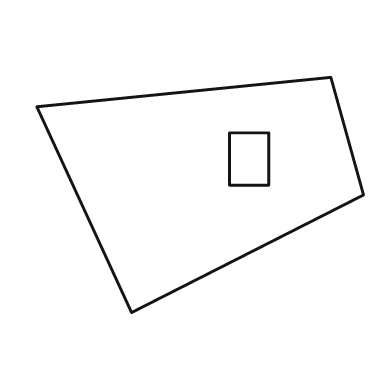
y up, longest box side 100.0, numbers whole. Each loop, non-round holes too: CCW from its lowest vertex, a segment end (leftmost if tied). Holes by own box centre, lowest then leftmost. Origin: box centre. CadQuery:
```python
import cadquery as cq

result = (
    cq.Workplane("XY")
    .moveTo(-21.0, -36.0)
    .lineTo(50.0, 0.0)
    .lineTo(40.0, 36.0)
    .lineTo(-50.0, 27.0)
    .close()
    .moveTo(9.0, 3.0)
    .lineTo(21.0, 3.0)
    .lineTo(21.0, 19.0)
    .lineTo(9.0, 19.0)
    .close()
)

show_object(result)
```